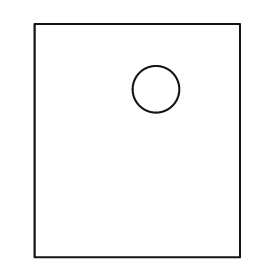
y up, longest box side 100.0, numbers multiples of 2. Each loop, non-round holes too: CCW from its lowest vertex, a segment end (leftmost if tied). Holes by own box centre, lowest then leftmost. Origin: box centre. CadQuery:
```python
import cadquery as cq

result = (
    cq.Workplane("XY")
    .moveTo(-44.0, -50.0)
    .lineTo(44.0, -50.0)
    .lineTo(44.0, 50.0)
    .lineTo(-44.0, 50.0)
    .close()
    .moveTo(8.0, 22.0)
    .circle(10.0)
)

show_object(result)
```